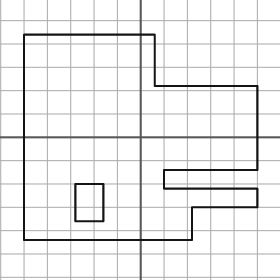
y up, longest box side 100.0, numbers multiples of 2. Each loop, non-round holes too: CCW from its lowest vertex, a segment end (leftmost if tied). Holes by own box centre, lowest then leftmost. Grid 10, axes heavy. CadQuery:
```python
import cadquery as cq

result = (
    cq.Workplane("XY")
    .moveTo(-50.0, -44.0)
    .lineTo(22.0, -44.0)
    .lineTo(22.0, -30.0)
    .lineTo(50.0, -30.0)
    .lineTo(50.0, -22.0)
    .lineTo(10.0, -22.0)
    .lineTo(10.0, -14.0)
    .lineTo(50.0, -14.0)
    .lineTo(50.0, 22.0)
    .lineTo(6.0, 22.0)
    .lineTo(6.0, 44.0)
    .lineTo(-50.0, 44.0)
    .close()
    .moveTo(-28.0, -36.0)
    .lineTo(-16.0, -36.0)
    .lineTo(-16.0, -20.0)
    .lineTo(-28.0, -20.0)
    .close()
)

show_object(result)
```